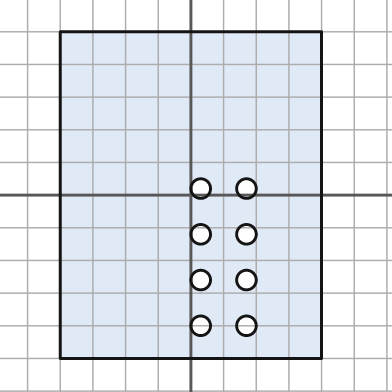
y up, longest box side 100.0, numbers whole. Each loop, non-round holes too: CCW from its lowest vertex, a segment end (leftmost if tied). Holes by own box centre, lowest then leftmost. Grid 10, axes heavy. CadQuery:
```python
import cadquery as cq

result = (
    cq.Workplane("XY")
    .moveTo(-40.0, -50.0)
    .lineTo(40.0, -50.0)
    .lineTo(40.0, 50.0)
    .lineTo(-40.0, 50.0)
    .close()
    .moveTo(3.0, -40.0)
    .circle(3.0)
    .moveTo(17.0, -40.0)
    .circle(3.0)
    .moveTo(3.0, -26.0)
    .circle(3.0)
    .moveTo(17.0, -26.0)
    .circle(3.0)
    .moveTo(3.0, -12.0)
    .circle(3.0)
    .moveTo(17.0, -12.0)
    .circle(3.0)
    .moveTo(3.0, 2.0)
    .circle(3.0)
    .moveTo(17.0, 2.0)
    .circle(3.0)
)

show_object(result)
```